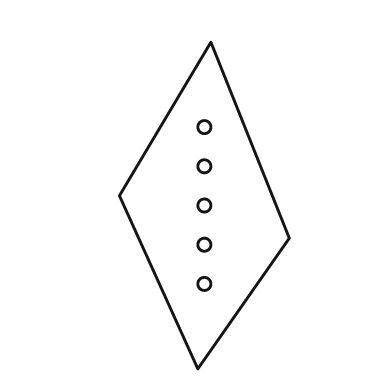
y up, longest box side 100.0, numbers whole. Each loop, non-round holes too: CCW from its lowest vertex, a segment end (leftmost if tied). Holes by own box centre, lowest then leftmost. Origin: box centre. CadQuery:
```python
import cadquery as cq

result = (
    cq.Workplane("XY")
    .moveTo(-2.0, -50.0)
    .lineTo(26.0, -10.0)
    .lineTo(2.0, 50.0)
    .lineTo(-26.0, 3.0)
    .close()
    .moveTo(0.0, -24.0)
    .circle(2.0)
    .moveTo(0.0, -12.0)
    .circle(2.0)
    .moveTo(0.0, 0.0)
    .circle(2.0)
    .moveTo(0.0, 12.0)
    .circle(2.0)
    .moveTo(0.0, 24.0)
    .circle(2.0)
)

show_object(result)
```